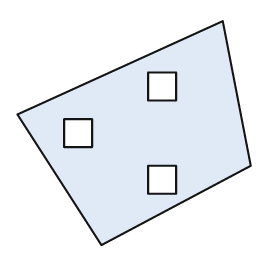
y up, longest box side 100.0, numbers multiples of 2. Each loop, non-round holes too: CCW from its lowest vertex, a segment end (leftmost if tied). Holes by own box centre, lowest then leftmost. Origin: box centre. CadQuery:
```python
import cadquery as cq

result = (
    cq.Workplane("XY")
    .moveTo(-14.0, -48.0)
    .lineTo(50.0, -14.0)
    .lineTo(38.0, 48.0)
    .lineTo(-50.0, 8.0)
    .close()
    .moveTo(6.0, -26.0)
    .lineTo(18.0, -26.0)
    .lineTo(18.0, -14.0)
    .lineTo(6.0, -14.0)
    .close()
    .moveTo(-30.0, -6.0)
    .lineTo(-18.0, -6.0)
    .lineTo(-18.0, 6.0)
    .lineTo(-30.0, 6.0)
    .close()
    .moveTo(6.0, 14.0)
    .lineTo(18.0, 14.0)
    .lineTo(18.0, 26.0)
    .lineTo(6.0, 26.0)
    .close()
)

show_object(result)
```